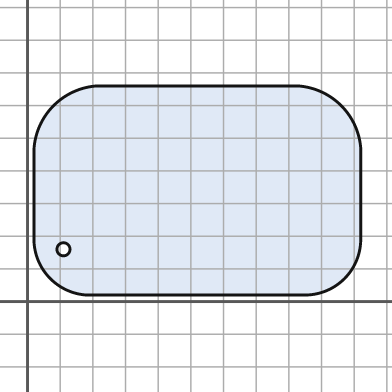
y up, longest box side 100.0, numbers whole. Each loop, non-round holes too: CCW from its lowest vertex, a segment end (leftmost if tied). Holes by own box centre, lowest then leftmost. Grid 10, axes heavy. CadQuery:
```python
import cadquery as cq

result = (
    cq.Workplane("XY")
    .moveTo(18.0, 2.0)
    .lineTo(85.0, 2.0)
    .threePointArc((97.0, 7.0), (102.0, 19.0))
    .lineTo(102.0, 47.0)
    .threePointArc((96.0, 60.0), (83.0, 66.0))
    .lineTo(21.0, 66.0)
    .threePointArc((8.0, 60.0), (2.0, 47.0))
    .lineTo(2.0, 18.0)
    .threePointArc((7.0, 7.0), (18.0, 2.0))
    .close()
    .moveTo(11.0, 16.0)
    .circle(2.0)
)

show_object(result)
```